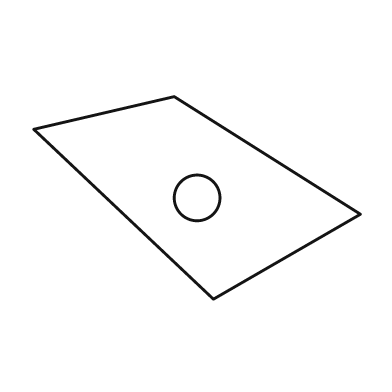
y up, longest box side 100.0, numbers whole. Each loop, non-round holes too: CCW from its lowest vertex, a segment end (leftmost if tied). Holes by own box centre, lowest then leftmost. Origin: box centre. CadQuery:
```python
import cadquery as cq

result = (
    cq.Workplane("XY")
    .moveTo(5.0, -31.0)
    .lineTo(50.0, -5.0)
    .lineTo(-7.0, 31.0)
    .lineTo(-50.0, 21.0)
    .close()
    .moveTo(0.0, 0.0)
    .circle(7.0)
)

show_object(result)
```